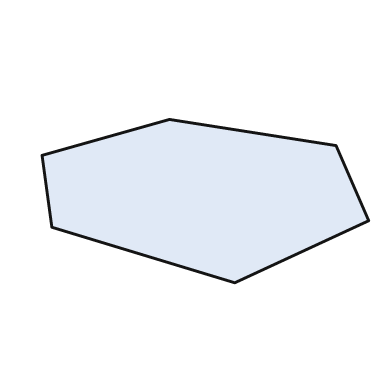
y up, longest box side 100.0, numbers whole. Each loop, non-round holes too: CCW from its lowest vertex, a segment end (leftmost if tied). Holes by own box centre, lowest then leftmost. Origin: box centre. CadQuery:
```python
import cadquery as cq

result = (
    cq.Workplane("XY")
    .moveTo(9.0, -25.0)
    .lineTo(50.0, -6.0)
    .lineTo(40.0, 17.0)
    .lineTo(-11.0, 25.0)
    .lineTo(-50.0, 14.0)
    .lineTo(-47.0, -8.0)
    .close()
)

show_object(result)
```